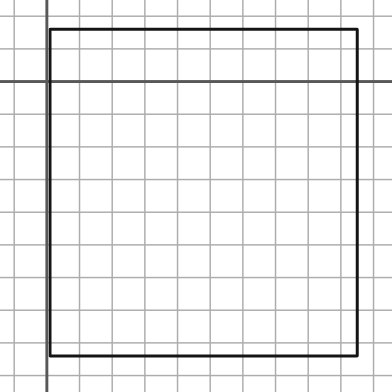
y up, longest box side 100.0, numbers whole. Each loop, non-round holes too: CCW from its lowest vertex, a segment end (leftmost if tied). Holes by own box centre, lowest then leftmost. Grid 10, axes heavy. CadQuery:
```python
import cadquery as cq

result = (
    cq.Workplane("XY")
    .moveTo(1.0, -84.0)
    .lineTo(95.0, -84.0)
    .lineTo(95.0, 16.0)
    .lineTo(1.0, 16.0)
    .close()
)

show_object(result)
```